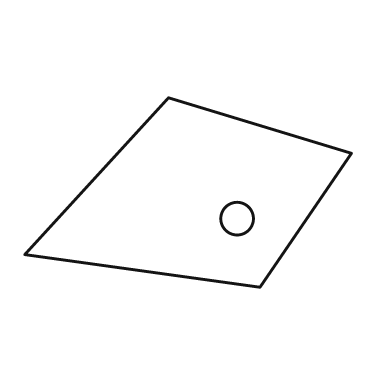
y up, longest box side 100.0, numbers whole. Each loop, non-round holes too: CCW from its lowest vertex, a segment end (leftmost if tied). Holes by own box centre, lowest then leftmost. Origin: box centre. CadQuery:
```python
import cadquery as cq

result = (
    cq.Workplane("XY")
    .moveTo(22.0, -29.0)
    .lineTo(50.0, 12.0)
    .lineTo(-6.0, 29.0)
    .lineTo(-50.0, -19.0)
    .close()
    .moveTo(15.0, -8.0)
    .circle(5.0)
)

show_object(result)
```